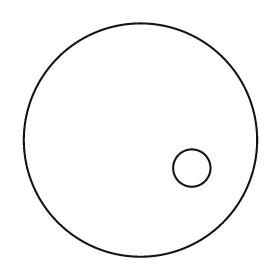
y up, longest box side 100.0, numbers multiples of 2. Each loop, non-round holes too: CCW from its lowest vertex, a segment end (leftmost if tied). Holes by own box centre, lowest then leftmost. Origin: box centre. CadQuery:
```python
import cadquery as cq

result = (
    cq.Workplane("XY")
    .moveTo(0.0, 0.0)
    .circle(50.0)
    .moveTo(22.0, -12.0)
    .circle(8.0)
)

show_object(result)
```